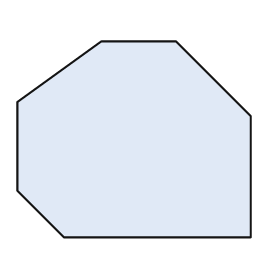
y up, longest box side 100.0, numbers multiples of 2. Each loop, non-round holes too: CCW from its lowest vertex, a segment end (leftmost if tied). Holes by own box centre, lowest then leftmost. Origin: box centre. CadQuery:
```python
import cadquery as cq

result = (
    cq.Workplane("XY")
    .moveTo(-30.0, -42.0)
    .lineTo(50.0, -42.0)
    .lineTo(50.0, 10.0)
    .lineTo(18.0, 42.0)
    .lineTo(-14.0, 42.0)
    .lineTo(-50.0, 16.0)
    .lineTo(-50.0, -22.0)
    .close()
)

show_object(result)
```